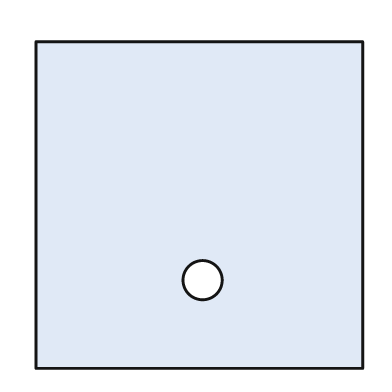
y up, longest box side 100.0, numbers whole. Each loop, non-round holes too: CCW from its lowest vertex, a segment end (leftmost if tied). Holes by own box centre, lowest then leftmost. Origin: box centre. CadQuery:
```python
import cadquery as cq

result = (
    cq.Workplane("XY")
    .moveTo(-50.0, -50.0)
    .lineTo(50.0, -50.0)
    .lineTo(50.0, 50.0)
    .lineTo(-50.0, 50.0)
    .close()
    .moveTo(1.0, -23.0)
    .circle(6.0)
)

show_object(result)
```